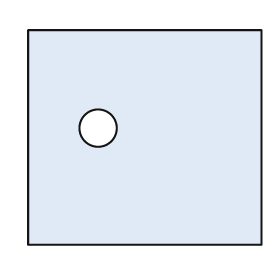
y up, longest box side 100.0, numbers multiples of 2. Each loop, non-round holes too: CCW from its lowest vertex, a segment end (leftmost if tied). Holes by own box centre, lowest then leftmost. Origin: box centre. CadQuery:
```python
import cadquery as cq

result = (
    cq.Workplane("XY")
    .moveTo(-50.0, -46.0)
    .lineTo(50.0, -46.0)
    .lineTo(50.0, 46.0)
    .lineTo(-50.0, 46.0)
    .close()
    .moveTo(-20.0, 4.0)
    .circle(8.0)
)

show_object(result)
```